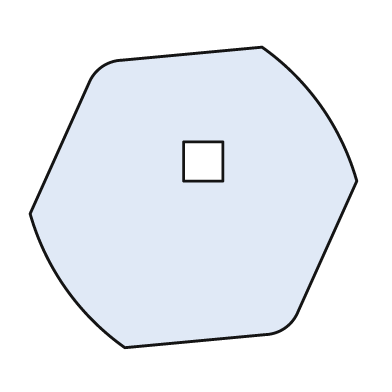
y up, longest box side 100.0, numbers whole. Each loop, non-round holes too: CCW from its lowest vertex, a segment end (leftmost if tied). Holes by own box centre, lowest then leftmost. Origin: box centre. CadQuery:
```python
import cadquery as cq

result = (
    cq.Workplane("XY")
    .moveTo(-21.0, -46.0)
    .lineTo(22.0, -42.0)
    .threePointArc((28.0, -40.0), (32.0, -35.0))
    .lineTo(50.0, 5.0)
    .threePointArc((39.0, 28.0), (21.0, 46.0))
    .lineTo(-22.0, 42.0)
    .threePointArc((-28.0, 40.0), (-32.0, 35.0))
    .lineTo(-50.0, -5.0)
    .threePointArc((-39.0, -28.0), (-21.0, -46.0))
    .close()
    .moveTo(-3.0, 5.0)
    .lineTo(9.0, 5.0)
    .lineTo(9.0, 17.0)
    .lineTo(-3.0, 17.0)
    .close()
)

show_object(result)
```